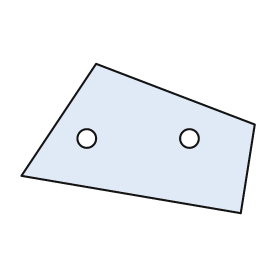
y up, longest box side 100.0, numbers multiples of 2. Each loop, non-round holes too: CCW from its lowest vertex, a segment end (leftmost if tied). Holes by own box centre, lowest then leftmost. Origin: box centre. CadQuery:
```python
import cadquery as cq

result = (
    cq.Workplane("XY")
    .moveTo(44.0, -32.0)
    .lineTo(50.0, 6.0)
    .lineTo(-18.0, 32.0)
    .lineTo(-50.0, -16.0)
    .close()
    .moveTo(-22.0, 0.0)
    .circle(4.0)
    .moveTo(22.0, 0.0)
    .circle(4.0)
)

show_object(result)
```